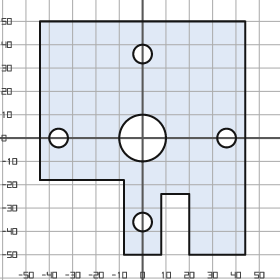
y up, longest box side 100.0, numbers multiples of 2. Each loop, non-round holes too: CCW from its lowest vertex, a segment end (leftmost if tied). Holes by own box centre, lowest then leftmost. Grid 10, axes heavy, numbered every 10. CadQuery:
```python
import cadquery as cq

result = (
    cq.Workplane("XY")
    .moveTo(-8.0, -50.0)
    .lineTo(8.0, -50.0)
    .lineTo(8.0, -24.0)
    .lineTo(20.0, -24.0)
    .lineTo(20.0, -50.0)
    .lineTo(44.0, -50.0)
    .lineTo(44.0, 50.0)
    .lineTo(-44.0, 50.0)
    .lineTo(-44.0, -18.0)
    .lineTo(-8.0, -18.0)
    .close()
    .moveTo(0.0, -36.0)
    .circle(4.0)
    .moveTo(-36.0, 0.0)
    .circle(4.0)
    .moveTo(0.0, 0.0)
    .circle(10.0)
    .moveTo(36.0, 0.0)
    .circle(4.0)
    .moveTo(0.0, 36.0)
    .circle(4.0)
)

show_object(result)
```